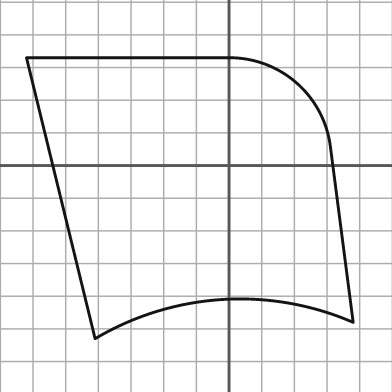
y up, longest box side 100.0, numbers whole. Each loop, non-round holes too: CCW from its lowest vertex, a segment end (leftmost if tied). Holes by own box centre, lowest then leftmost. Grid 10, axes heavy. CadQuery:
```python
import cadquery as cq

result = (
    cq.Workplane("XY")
    .moveTo(-41.0, -53.0)
    .threePointArc((-2.0, -41.0), (38.0, -48.0))
    .lineTo(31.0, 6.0)
    .threePointArc((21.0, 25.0), (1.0, 33.0))
    .lineTo(-62.0, 33.0)
    .close()
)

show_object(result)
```